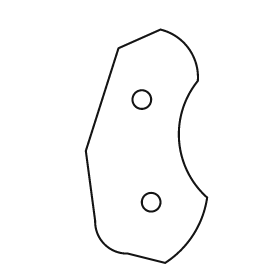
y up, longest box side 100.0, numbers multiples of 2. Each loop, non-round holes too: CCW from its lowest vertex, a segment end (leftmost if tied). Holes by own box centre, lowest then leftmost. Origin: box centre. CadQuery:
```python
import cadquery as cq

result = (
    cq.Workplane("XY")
    .moveTo(8.0, -50.0)
    .threePointArc((20.0, -38.0), (26.0, -22.0))
    .threePointArc((14.0, 2.0), (22.0, 28.0))
    .threePointArc((18.0, 42.0), (6.0, 50.0))
    .lineTo(-12.0, 42.0)
    .lineTo(-26.0, -2.0)
    .lineTo(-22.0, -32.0)
    .threePointArc((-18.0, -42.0), (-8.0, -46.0))
    .close()
    .moveTo(2.0, -24.0)
    .circle(4.0)
    .moveTo(-2.0, 20.0)
    .circle(4.0)
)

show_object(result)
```